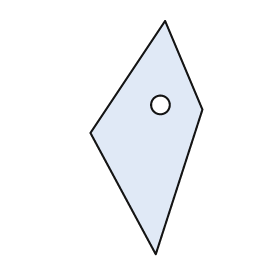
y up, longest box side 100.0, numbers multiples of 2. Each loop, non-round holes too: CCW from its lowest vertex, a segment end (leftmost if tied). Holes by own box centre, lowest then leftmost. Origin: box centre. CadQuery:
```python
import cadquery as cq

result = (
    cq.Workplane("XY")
    .moveTo(4.0, -50.0)
    .lineTo(24.0, 12.0)
    .lineTo(8.0, 50.0)
    .lineTo(-24.0, 2.0)
    .close()
    .moveTo(6.0, 14.0)
    .circle(4.0)
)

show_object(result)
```